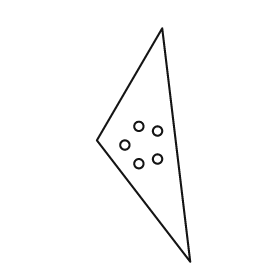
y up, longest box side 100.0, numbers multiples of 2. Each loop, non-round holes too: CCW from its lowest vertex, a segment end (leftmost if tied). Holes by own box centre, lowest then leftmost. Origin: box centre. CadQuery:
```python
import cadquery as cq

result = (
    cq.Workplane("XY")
    .moveTo(20.0, -50.0)
    .lineTo(8.0, 50.0)
    .lineTo(-20.0, 2.0)
    .close()
    .moveTo(-2.0, -8.0)
    .circle(2.0)
    .moveTo(6.0, -6.0)
    .circle(2.0)
    .moveTo(-8.0, 0.0)
    .circle(2.0)
    .moveTo(6.0, 6.0)
    .circle(2.0)
    .moveTo(-2.0, 8.0)
    .circle(2.0)
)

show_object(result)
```